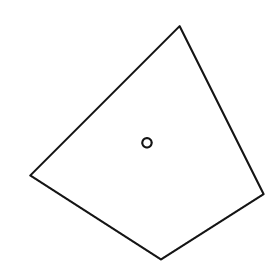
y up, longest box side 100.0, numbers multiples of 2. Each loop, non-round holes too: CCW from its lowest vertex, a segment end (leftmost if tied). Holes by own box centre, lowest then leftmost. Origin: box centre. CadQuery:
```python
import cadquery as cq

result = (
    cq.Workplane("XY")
    .moveTo(6.0, -50.0)
    .lineTo(50.0, -22.0)
    .lineTo(14.0, 50.0)
    .lineTo(-50.0, -14.0)
    .close()
    .moveTo(0.0, 0.0)
    .circle(2.0)
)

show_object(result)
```